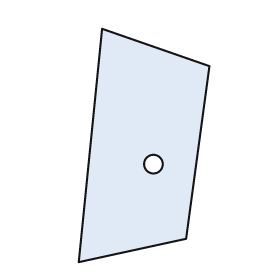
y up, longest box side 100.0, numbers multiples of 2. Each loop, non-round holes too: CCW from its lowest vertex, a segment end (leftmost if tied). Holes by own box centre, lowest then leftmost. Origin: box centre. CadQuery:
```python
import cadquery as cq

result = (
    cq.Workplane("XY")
    .moveTo(-28.0, -50.0)
    .lineTo(18.0, -40.0)
    .lineTo(28.0, 34.0)
    .lineTo(-18.0, 50.0)
    .close()
    .moveTo(4.0, -8.0)
    .circle(4.0)
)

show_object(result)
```